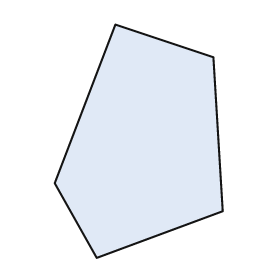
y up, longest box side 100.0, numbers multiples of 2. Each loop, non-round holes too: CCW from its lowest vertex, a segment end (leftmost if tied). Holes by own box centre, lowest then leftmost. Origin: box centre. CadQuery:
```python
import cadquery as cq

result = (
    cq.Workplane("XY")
    .moveTo(-18.0, -50.0)
    .lineTo(36.0, -30.0)
    .lineTo(32.0, 36.0)
    .lineTo(-10.0, 50.0)
    .lineTo(-36.0, -18.0)
    .close()
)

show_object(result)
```